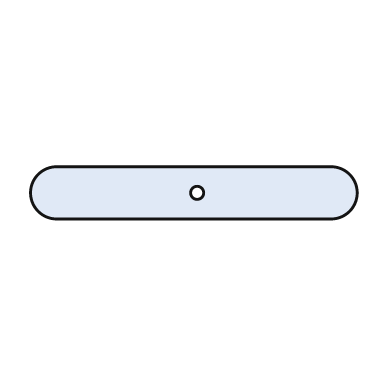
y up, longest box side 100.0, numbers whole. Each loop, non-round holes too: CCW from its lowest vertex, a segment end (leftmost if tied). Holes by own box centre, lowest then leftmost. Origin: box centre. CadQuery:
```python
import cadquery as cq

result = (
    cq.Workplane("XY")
    .moveTo(-42.0, -8.0)
    .lineTo(42.0, -8.0)
    .threePointArc((50.0, 0.0), (42.0, 8.0))
    .lineTo(-42.0, 8.0)
    .threePointArc((-50.0, 0.0), (-42.0, -8.0))
    .close()
    .moveTo(1.0, 0.0)
    .circle(2.0)
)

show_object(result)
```